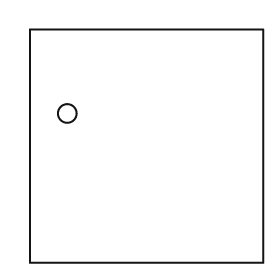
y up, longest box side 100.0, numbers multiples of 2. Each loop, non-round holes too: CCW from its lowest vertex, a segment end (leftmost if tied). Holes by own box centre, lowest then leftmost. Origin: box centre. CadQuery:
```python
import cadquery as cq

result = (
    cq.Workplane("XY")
    .moveTo(-50.0, -50.0)
    .lineTo(50.0, -50.0)
    .lineTo(50.0, 50.0)
    .lineTo(-50.0, 50.0)
    .close()
    .moveTo(-34.0, 14.0)
    .circle(4.0)
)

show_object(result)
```